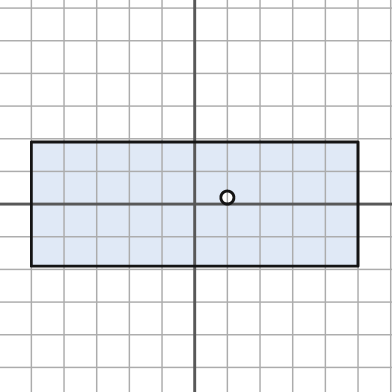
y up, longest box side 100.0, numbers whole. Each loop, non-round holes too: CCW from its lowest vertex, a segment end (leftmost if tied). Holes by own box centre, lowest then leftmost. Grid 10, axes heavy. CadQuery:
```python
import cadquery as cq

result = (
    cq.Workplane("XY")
    .moveTo(-50.0, -19.0)
    .lineTo(50.0, -19.0)
    .lineTo(50.0, 19.0)
    .lineTo(-50.0, 19.0)
    .close()
    .moveTo(10.0, 2.0)
    .circle(2.0)
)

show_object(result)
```